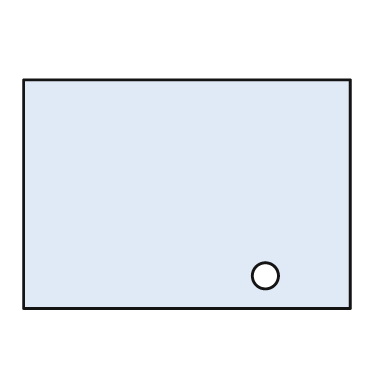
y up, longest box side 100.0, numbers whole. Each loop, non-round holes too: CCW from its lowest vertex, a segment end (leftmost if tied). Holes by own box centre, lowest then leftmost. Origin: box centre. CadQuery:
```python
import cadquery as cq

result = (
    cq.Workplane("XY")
    .moveTo(-50.0, -35.0)
    .lineTo(50.0, -35.0)
    .lineTo(50.0, 35.0)
    .lineTo(-50.0, 35.0)
    .close()
    .moveTo(24.0, -25.0)
    .circle(4.0)
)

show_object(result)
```